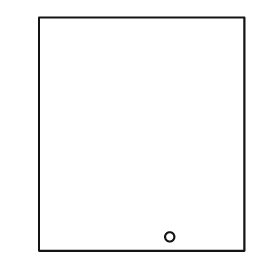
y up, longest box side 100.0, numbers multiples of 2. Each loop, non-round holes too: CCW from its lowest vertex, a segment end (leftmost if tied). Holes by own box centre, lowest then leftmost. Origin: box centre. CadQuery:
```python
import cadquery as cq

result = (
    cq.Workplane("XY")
    .moveTo(-44.0, -50.0)
    .lineTo(44.0, -50.0)
    .lineTo(44.0, 50.0)
    .lineTo(-44.0, 50.0)
    .close()
    .moveTo(12.0, -44.0)
    .circle(2.0)
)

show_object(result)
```